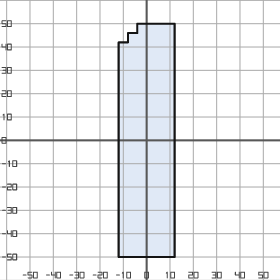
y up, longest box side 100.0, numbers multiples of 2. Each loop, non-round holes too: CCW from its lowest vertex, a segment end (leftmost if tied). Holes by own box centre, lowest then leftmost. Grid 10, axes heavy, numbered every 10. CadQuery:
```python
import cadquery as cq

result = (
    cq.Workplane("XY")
    .moveTo(-12.0, -50.0)
    .lineTo(12.0, -50.0)
    .lineTo(12.0, 50.0)
    .lineTo(-4.0, 50.0)
    .lineTo(-4.0, 46.0)
    .lineTo(-8.0, 46.0)
    .lineTo(-8.0, 42.0)
    .lineTo(-12.0, 42.0)
    .close()
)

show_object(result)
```